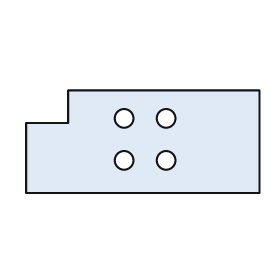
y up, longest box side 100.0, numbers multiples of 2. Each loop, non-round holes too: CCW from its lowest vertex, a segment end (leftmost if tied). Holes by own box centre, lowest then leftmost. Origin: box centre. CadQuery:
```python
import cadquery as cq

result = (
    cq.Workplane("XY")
    .moveTo(-50.0, -22.0)
    .lineTo(50.0, -22.0)
    .lineTo(50.0, 22.0)
    .lineTo(-32.0, 22.0)
    .lineTo(-32.0, 8.0)
    .lineTo(-50.0, 8.0)
    .close()
    .moveTo(-8.0, -8.0)
    .circle(4.0)
    .moveTo(10.0, -8.0)
    .circle(4.0)
    .moveTo(-8.0, 10.0)
    .circle(4.0)
    .moveTo(10.0, 10.0)
    .circle(4.0)
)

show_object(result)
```